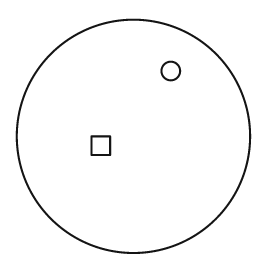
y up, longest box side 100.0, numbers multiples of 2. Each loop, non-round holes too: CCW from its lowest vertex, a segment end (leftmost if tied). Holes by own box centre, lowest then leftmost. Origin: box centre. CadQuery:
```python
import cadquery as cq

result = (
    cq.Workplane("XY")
    .moveTo(0.0, 0.0)
    .circle(50.0)
    .moveTo(-18.0, -8.0)
    .lineTo(-10.0, -8.0)
    .lineTo(-10.0, 0.0)
    .lineTo(-18.0, 0.0)
    .close()
    .moveTo(16.0, 28.0)
    .circle(4.0)
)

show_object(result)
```